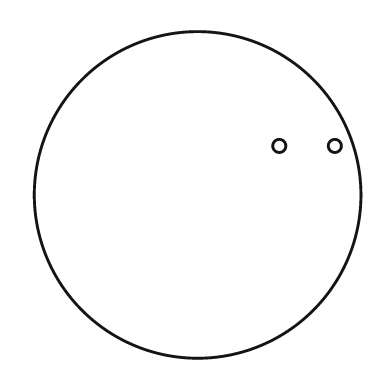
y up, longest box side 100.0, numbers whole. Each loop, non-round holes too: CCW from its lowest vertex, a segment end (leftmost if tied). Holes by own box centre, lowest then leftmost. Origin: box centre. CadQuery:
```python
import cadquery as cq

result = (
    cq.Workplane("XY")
    .moveTo(0.0, 0.0)
    .circle(50.0)
    .moveTo(25.0, 15.0)
    .circle(2.0)
    .moveTo(42.0, 15.0)
    .circle(2.0)
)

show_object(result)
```